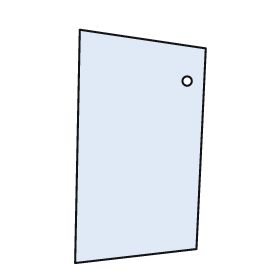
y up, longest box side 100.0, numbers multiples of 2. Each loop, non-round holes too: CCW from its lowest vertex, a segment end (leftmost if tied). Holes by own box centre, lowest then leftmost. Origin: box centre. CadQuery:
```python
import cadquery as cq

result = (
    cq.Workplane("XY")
    .moveTo(-28.0, -50.0)
    .lineTo(24.0, -44.0)
    .lineTo(28.0, 42.0)
    .lineTo(-26.0, 50.0)
    .close()
    .moveTo(20.0, 28.0)
    .circle(2.0)
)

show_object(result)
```